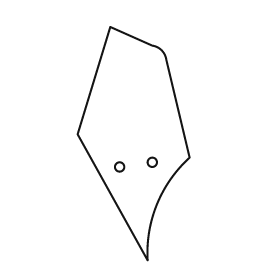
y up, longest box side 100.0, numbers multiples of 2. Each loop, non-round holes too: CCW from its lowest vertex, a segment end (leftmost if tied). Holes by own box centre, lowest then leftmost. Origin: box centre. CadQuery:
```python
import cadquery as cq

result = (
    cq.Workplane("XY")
    .moveTo(6.0, -50.0)
    .threePointArc((10.0, -26.0), (24.0, -6.0))
    .lineTo(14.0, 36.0)
    .threePointArc((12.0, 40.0), (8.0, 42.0))
    .lineTo(-10.0, 50.0)
    .lineTo(-24.0, 4.0)
    .close()
    .moveTo(-6.0, -10.0)
    .circle(2.0)
    .moveTo(8.0, -8.0)
    .circle(2.0)
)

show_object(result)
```